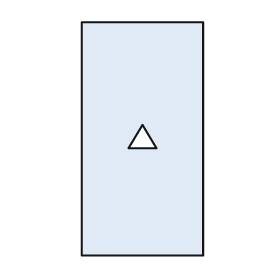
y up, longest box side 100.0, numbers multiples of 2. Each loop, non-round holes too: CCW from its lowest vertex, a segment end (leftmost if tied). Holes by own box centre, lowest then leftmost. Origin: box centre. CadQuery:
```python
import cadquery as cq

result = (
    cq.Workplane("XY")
    .moveTo(-26.0, -50.0)
    .lineTo(26.0, -50.0)
    .lineTo(26.0, 50.0)
    .lineTo(-26.0, 50.0)
    .close()
    .moveTo(-6.0, -4.0)
    .lineTo(6.0, -4.0)
    .lineTo(0.0, 6.0)
    .close()
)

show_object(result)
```